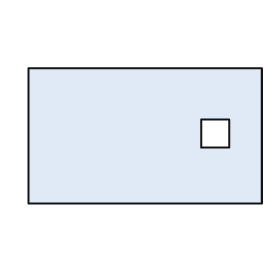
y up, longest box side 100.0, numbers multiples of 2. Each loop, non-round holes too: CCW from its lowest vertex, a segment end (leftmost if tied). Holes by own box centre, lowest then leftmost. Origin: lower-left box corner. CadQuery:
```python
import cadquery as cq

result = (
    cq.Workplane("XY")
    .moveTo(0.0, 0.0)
    .lineTo(100.0, 0.0)
    .lineTo(100.0, 58.0)
    .lineTo(0.0, 58.0)
    .close()
    .moveTo(74.0, 24.0)
    .lineTo(86.0, 24.0)
    .lineTo(86.0, 36.0)
    .lineTo(74.0, 36.0)
    .close()
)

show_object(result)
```